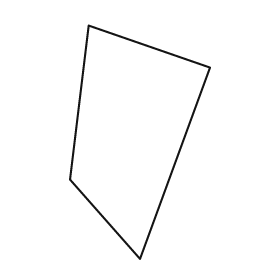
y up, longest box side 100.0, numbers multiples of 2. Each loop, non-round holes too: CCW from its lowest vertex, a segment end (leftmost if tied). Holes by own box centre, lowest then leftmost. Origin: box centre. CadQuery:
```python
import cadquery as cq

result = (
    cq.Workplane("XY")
    .moveTo(0.0, -50.0)
    .lineTo(30.0, 32.0)
    .lineTo(-22.0, 50.0)
    .lineTo(-30.0, -16.0)
    .close()
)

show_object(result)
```